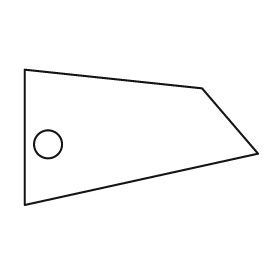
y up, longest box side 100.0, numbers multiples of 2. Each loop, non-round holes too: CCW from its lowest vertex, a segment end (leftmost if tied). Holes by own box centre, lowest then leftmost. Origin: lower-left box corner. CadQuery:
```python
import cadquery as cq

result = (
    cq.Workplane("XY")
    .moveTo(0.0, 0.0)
    .lineTo(100.0, 22.0)
    .lineTo(76.0, 50.0)
    .lineTo(0.0, 58.0)
    .close()
    .moveTo(10.0, 26.0)
    .circle(6.0)
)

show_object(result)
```